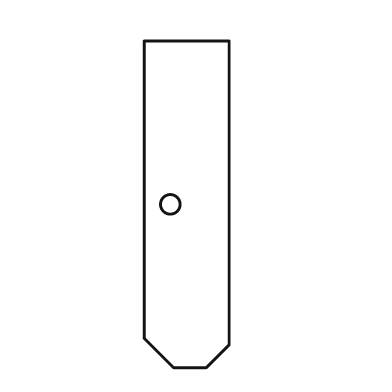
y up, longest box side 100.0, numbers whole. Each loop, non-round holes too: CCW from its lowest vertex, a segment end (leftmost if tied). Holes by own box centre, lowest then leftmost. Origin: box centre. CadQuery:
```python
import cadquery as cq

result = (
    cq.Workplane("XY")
    .moveTo(-4.0, -50.0)
    .lineTo(6.0, -50.0)
    .lineTo(13.0, -43.0)
    .lineTo(13.0, 50.0)
    .lineTo(-13.0, 50.0)
    .lineTo(-13.0, -41.0)
    .close()
    .moveTo(-5.0, 0.0)
    .circle(3.0)
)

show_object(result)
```